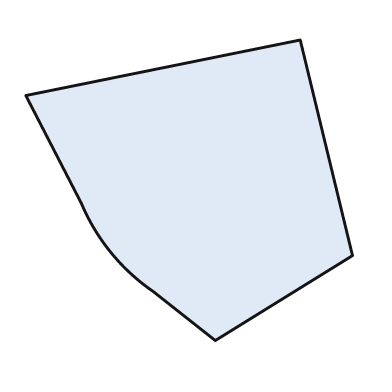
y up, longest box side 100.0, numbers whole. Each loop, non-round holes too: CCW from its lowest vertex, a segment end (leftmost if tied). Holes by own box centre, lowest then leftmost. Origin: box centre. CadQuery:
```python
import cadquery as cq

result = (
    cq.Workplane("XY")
    .moveTo(8.0, -46.0)
    .lineTo(50.0, -20.0)
    .lineTo(34.0, 46.0)
    .lineTo(-50.0, 29.0)
    .lineTo(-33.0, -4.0)
    .threePointArc((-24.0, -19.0), (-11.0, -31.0))
    .close()
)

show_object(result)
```